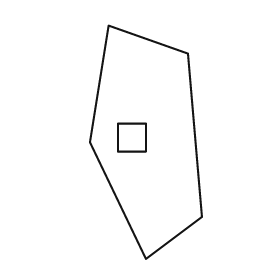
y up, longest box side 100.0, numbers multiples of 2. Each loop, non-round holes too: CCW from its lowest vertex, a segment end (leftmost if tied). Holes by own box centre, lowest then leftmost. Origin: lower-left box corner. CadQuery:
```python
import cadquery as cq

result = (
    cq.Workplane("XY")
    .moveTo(24.0, 0.0)
    .lineTo(48.0, 18.0)
    .lineTo(42.0, 88.0)
    .lineTo(8.0, 100.0)
    .lineTo(0.0, 50.0)
    .close()
    .moveTo(12.0, 46.0)
    .lineTo(24.0, 46.0)
    .lineTo(24.0, 58.0)
    .lineTo(12.0, 58.0)
    .close()
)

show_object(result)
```